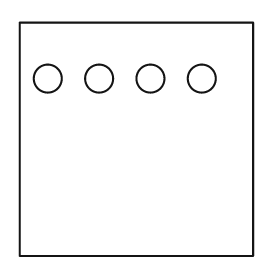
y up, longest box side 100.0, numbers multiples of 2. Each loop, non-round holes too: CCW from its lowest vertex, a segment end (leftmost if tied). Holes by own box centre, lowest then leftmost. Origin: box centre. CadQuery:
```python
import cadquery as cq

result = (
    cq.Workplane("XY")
    .moveTo(-50.0, -50.0)
    .lineTo(50.0, -50.0)
    .lineTo(50.0, 50.0)
    .lineTo(-50.0, 50.0)
    .close()
    .moveTo(-38.0, 26.0)
    .circle(6.0)
    .moveTo(-16.0, 26.0)
    .circle(6.0)
    .moveTo(6.0, 26.0)
    .circle(6.0)
    .moveTo(28.0, 26.0)
    .circle(6.0)
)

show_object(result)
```